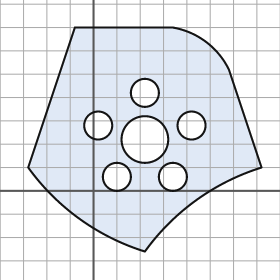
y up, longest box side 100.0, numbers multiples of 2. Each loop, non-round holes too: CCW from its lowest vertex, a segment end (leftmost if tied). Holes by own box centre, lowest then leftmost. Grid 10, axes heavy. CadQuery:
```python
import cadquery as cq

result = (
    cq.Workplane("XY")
    .moveTo(22.0, -26.0)
    .threePointArc((44.0, -4.0), (72.0, 10.0))
    .lineTo(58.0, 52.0)
    .threePointArc((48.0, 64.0), (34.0, 70.0))
    .lineTo(-8.0, 70.0)
    .lineTo(-28.0, 10.0)
    .threePointArc((-6.0, -12.0), (22.0, -26.0))
    .close()
    .moveTo(10.0, 6.0)
    .circle(6.0)
    .moveTo(34.0, 6.0)
    .circle(6.0)
    .moveTo(22.0, 22.0)
    .circle(10.0)
    .moveTo(2.0, 28.0)
    .circle(6.0)
    .moveTo(42.0, 28.0)
    .circle(6.0)
    .moveTo(22.0, 42.0)
    .circle(6.0)
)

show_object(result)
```